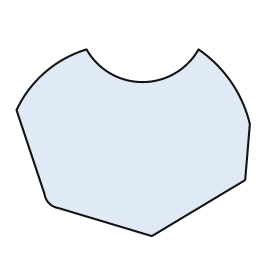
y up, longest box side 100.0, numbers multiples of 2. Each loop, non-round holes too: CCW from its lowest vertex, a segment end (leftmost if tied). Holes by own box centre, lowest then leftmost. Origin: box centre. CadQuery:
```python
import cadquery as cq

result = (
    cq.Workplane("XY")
    .moveTo(8.0, -40.0)
    .lineTo(48.0, -16.0)
    .lineTo(50.0, 8.0)
    .threePointArc((42.0, 26.0), (28.0, 40.0))
    .threePointArc((4.0, 26.0), (-20.0, 40.0))
    .threePointArc((-38.0, 30.0), (-50.0, 14.0))
    .lineTo(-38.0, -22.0)
    .threePointArc((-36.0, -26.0), (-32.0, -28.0))
    .close()
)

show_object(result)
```